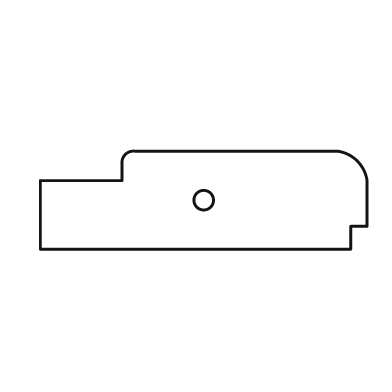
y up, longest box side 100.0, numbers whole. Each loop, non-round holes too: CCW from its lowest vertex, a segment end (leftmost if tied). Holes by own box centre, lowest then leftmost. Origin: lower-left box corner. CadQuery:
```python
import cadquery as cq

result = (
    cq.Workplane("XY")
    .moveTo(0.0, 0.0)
    .lineTo(95.0, 0.0)
    .lineTo(95.0, 7.0)
    .lineTo(100.0, 7.0)
    .lineTo(100.0, 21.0)
    .threePointArc((97.0, 27.0), (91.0, 30.0))
    .lineTo(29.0, 30.0)
    .threePointArc((26.0, 29.0), (25.0, 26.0))
    .lineTo(25.0, 21.0)
    .lineTo(0.0, 21.0)
    .close()
    .moveTo(50.0, 15.0)
    .circle(3.0)
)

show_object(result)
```